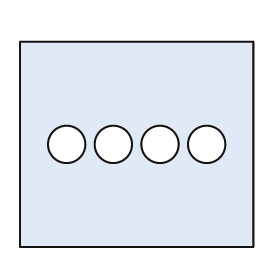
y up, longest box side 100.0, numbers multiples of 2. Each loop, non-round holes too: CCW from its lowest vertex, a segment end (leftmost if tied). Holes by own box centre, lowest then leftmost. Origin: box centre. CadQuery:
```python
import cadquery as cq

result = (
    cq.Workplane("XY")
    .moveTo(-50.0, -44.0)
    .lineTo(50.0, -44.0)
    .lineTo(50.0, 44.0)
    .lineTo(-50.0, 44.0)
    .close()
    .moveTo(-30.0, 0.0)
    .circle(8.0)
    .moveTo(-10.0, 0.0)
    .circle(8.0)
    .moveTo(10.0, 0.0)
    .circle(8.0)
    .moveTo(30.0, 0.0)
    .circle(8.0)
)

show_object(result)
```